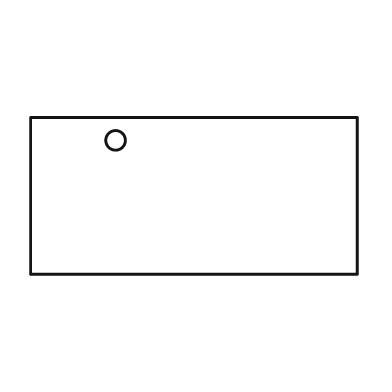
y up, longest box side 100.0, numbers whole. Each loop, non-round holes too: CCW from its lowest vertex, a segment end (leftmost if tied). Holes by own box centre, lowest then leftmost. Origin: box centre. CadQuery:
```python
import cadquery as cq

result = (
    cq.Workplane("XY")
    .moveTo(-50.0, -24.0)
    .lineTo(50.0, -24.0)
    .lineTo(50.0, 24.0)
    .lineTo(-50.0, 24.0)
    .close()
    .moveTo(-24.0, 17.0)
    .circle(3.0)
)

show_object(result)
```